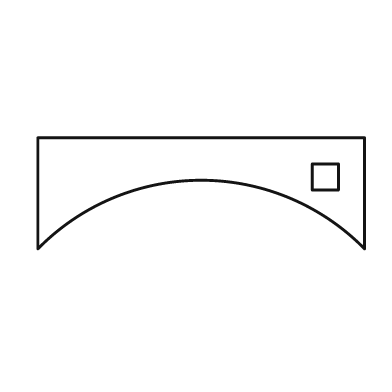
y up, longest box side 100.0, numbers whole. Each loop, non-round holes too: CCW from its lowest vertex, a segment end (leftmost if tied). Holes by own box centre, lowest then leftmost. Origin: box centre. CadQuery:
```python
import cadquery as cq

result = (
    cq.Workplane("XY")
    .moveTo(-50.0, -17.0)
    .threePointArc((0.0, 4.0), (50.0, -17.0))
    .lineTo(50.0, 17.0)
    .lineTo(-50.0, 17.0)
    .close()
    .moveTo(34.0, 1.0)
    .lineTo(42.0, 1.0)
    .lineTo(42.0, 9.0)
    .lineTo(34.0, 9.0)
    .close()
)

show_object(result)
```